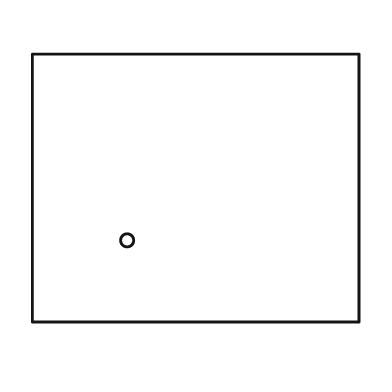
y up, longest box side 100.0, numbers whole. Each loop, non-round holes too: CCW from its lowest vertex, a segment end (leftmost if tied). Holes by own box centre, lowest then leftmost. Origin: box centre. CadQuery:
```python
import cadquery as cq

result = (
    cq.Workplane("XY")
    .moveTo(-50.0, -41.0)
    .lineTo(50.0, -41.0)
    .lineTo(50.0, 41.0)
    .lineTo(-50.0, 41.0)
    .close()
    .moveTo(-21.0, -16.0)
    .circle(2.0)
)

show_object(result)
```